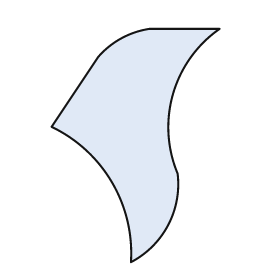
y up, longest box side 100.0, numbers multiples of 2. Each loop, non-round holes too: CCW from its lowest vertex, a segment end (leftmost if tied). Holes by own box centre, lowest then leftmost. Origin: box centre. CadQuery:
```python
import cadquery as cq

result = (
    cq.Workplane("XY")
    .moveTo(-2.0, -50.0)
    .threePointArc((14.0, -34.0), (18.0, -12.0))
    .threePointArc((16.0, 22.0), (36.0, 50.0))
    .lineTo(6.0, 50.0)
    .threePointArc((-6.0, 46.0), (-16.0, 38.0))
    .lineTo(-36.0, 8.0)
    .threePointArc((-10.0, -16.0), (-2.0, -50.0))
    .close()
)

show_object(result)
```